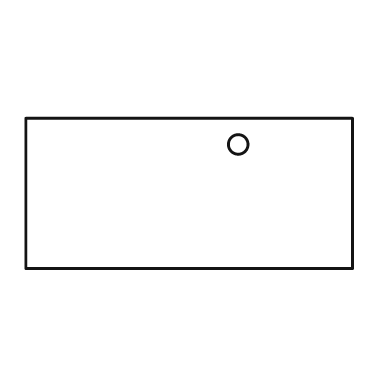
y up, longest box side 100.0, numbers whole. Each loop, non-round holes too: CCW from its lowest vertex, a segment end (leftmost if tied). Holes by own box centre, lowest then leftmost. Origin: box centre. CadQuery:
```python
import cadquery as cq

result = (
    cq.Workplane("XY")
    .moveTo(-50.0, -23.0)
    .lineTo(50.0, -23.0)
    .lineTo(50.0, 23.0)
    .lineTo(-50.0, 23.0)
    .close()
    .moveTo(15.0, 15.0)
    .circle(3.0)
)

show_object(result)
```